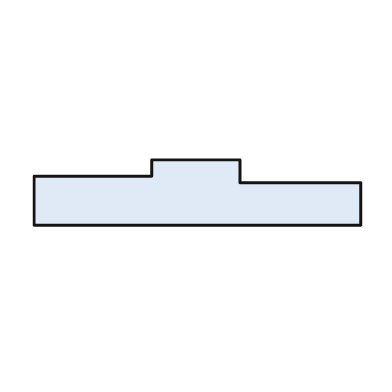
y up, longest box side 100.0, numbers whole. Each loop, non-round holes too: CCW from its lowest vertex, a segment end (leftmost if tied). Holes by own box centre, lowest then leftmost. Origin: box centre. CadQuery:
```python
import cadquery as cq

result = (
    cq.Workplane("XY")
    .moveTo(-50.0, -10.0)
    .lineTo(50.0, -10.0)
    .lineTo(50.0, 3.0)
    .lineTo(13.0, 3.0)
    .lineTo(13.0, 10.0)
    .lineTo(-14.0, 10.0)
    .lineTo(-14.0, 5.0)
    .lineTo(-50.0, 5.0)
    .close()
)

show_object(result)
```